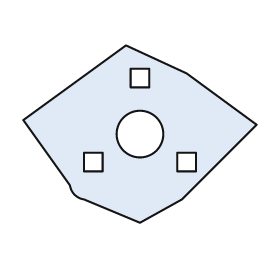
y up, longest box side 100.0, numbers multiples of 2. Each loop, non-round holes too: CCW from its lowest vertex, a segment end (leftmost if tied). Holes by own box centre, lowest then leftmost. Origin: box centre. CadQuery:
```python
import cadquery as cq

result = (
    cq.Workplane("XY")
    .moveTo(0.0, -38.0)
    .lineTo(18.0, -28.0)
    .lineTo(50.0, 4.0)
    .lineTo(20.0, 26.0)
    .lineTo(-6.0, 38.0)
    .lineTo(-50.0, 6.0)
    .lineTo(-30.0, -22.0)
    .threePointArc((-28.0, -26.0), (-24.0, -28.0))
    .close()
    .moveTo(-24.0, -16.0)
    .lineTo(-16.0, -16.0)
    .lineTo(-16.0, -8.0)
    .lineTo(-24.0, -8.0)
    .close()
    .moveTo(16.0, -16.0)
    .lineTo(24.0, -16.0)
    .lineTo(24.0, -8.0)
    .lineTo(16.0, -8.0)
    .close()
    .moveTo(0.0, 0.0)
    .circle(10.0)
    .moveTo(-4.0, 20.0)
    .lineTo(4.0, 20.0)
    .lineTo(4.0, 28.0)
    .lineTo(-4.0, 28.0)
    .close()
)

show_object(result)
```